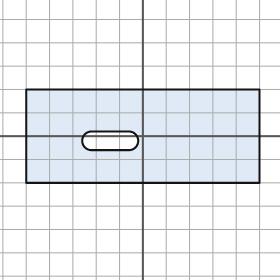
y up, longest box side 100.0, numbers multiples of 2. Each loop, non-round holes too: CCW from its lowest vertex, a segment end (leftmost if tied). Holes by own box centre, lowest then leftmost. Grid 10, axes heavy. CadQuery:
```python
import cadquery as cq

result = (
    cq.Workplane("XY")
    .moveTo(-50.0, -20.0)
    .lineTo(50.0, -20.0)
    .lineTo(50.0, 20.0)
    .lineTo(-50.0, 20.0)
    .close()
    .moveTo(-22.0, -6.0)
    .lineTo(-6.0, -6.0)
    .threePointArc((-2.0, -2.0), (-6.0, 2.0))
    .lineTo(-22.0, 2.0)
    .threePointArc((-26.0, -2.0), (-22.0, -6.0))
    .close()
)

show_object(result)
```